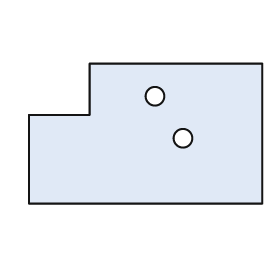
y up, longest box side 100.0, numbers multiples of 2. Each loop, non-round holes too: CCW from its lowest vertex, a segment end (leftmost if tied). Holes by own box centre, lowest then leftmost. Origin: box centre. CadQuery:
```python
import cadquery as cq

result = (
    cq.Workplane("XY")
    .moveTo(-50.0, -30.0)
    .lineTo(50.0, -30.0)
    .lineTo(50.0, 30.0)
    .lineTo(-24.0, 30.0)
    .lineTo(-24.0, 8.0)
    .lineTo(-50.0, 8.0)
    .close()
    .moveTo(16.0, -2.0)
    .circle(4.0)
    .moveTo(4.0, 16.0)
    .circle(4.0)
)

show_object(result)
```